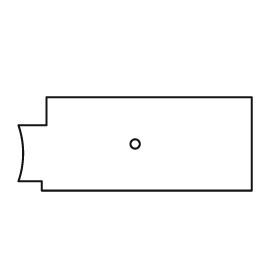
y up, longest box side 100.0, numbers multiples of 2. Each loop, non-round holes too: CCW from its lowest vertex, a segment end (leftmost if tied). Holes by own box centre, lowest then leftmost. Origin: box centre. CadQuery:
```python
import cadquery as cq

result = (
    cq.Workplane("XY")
    .moveTo(-40.0, -20.0)
    .lineTo(50.0, -20.0)
    .lineTo(50.0, 20.0)
    .lineTo(-38.0, 20.0)
    .lineTo(-38.0, 8.0)
    .lineTo(-50.0, 8.0)
    .threePointArc((-48.0, -4.0), (-50.0, -16.0))
    .lineTo(-40.0, -16.0)
    .close()
    .moveTo(0.0, 0.0)
    .circle(2.0)
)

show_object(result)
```